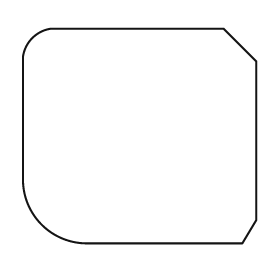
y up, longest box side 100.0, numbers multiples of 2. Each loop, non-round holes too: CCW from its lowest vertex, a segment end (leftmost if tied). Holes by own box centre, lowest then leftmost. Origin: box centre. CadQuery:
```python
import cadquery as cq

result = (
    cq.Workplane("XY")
    .moveTo(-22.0, -46.0)
    .lineTo(44.0, -46.0)
    .lineTo(50.0, -36.0)
    .lineTo(50.0, 32.0)
    .lineTo(36.0, 46.0)
    .lineTo(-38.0, 46.0)
    .threePointArc((-46.0, 42.0), (-50.0, 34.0))
    .lineTo(-50.0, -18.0)
    .threePointArc((-42.0, -38.0), (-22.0, -46.0))
    .close()
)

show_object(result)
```